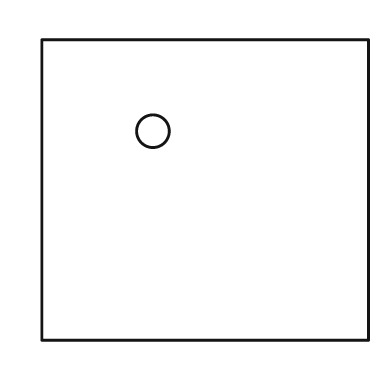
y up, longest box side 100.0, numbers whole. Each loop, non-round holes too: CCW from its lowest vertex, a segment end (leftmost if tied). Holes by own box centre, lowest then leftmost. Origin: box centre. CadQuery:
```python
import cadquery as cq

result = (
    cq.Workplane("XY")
    .moveTo(-50.0, -46.0)
    .lineTo(50.0, -46.0)
    .lineTo(50.0, 46.0)
    .lineTo(-50.0, 46.0)
    .close()
    .moveTo(-16.0, 18.0)
    .circle(5.0)
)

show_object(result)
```